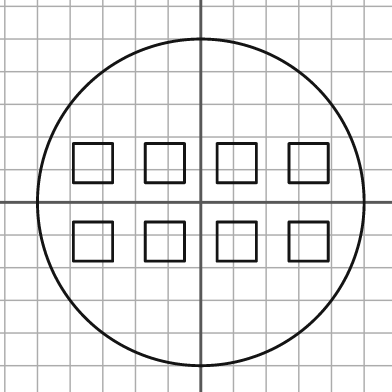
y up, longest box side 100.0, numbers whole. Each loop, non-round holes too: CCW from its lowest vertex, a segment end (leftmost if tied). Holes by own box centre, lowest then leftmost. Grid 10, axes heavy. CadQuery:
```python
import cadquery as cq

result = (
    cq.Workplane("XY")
    .moveTo(0.0, 0.0)
    .circle(50.0)
    .moveTo(-39.0, -18.0)
    .lineTo(-27.0, -18.0)
    .lineTo(-27.0, -6.0)
    .lineTo(-39.0, -6.0)
    .close()
    .moveTo(-17.0, -18.0)
    .lineTo(-5.0, -18.0)
    .lineTo(-5.0, -6.0)
    .lineTo(-17.0, -6.0)
    .close()
    .moveTo(5.0, -18.0)
    .lineTo(17.0, -18.0)
    .lineTo(17.0, -6.0)
    .lineTo(5.0, -6.0)
    .close()
    .moveTo(27.0, -18.0)
    .lineTo(39.0, -18.0)
    .lineTo(39.0, -6.0)
    .lineTo(27.0, -6.0)
    .close()
    .moveTo(-39.0, 6.0)
    .lineTo(-27.0, 6.0)
    .lineTo(-27.0, 18.0)
    .lineTo(-39.0, 18.0)
    .close()
    .moveTo(-17.0, 6.0)
    .lineTo(-5.0, 6.0)
    .lineTo(-5.0, 18.0)
    .lineTo(-17.0, 18.0)
    .close()
    .moveTo(5.0, 6.0)
    .lineTo(17.0, 6.0)
    .lineTo(17.0, 18.0)
    .lineTo(5.0, 18.0)
    .close()
    .moveTo(27.0, 6.0)
    .lineTo(39.0, 6.0)
    .lineTo(39.0, 18.0)
    .lineTo(27.0, 18.0)
    .close()
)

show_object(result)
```